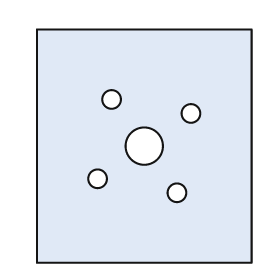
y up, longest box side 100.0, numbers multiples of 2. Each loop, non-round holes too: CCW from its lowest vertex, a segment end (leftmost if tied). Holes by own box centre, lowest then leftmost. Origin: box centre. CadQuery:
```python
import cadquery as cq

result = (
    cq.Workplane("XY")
    .moveTo(-46.0, -50.0)
    .lineTo(46.0, -50.0)
    .lineTo(46.0, 50.0)
    .lineTo(-46.0, 50.0)
    .close()
    .moveTo(14.0, -20.0)
    .circle(4.0)
    .moveTo(-20.0, -14.0)
    .circle(4.0)
    .moveTo(0.0, 0.0)
    .circle(8.0)
    .moveTo(20.0, 14.0)
    .circle(4.0)
    .moveTo(-14.0, 20.0)
    .circle(4.0)
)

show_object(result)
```